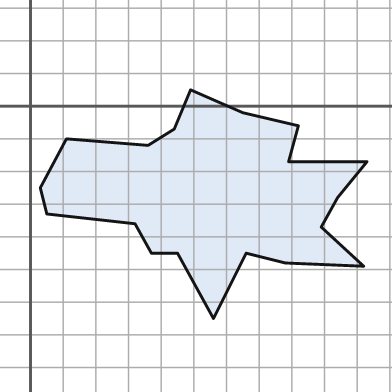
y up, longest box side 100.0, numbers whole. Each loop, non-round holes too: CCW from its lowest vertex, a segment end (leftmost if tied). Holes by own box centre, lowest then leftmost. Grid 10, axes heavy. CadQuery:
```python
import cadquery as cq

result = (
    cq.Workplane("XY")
    .moveTo(56.0, -65.0)
    .lineTo(66.0, -45.0)
    .lineTo(78.0, -48.0)
    .lineTo(102.0, -49.0)
    .lineTo(89.0, -37.0)
    .lineTo(94.0, -28.0)
    .lineTo(103.0, -17.0)
    .lineTo(79.0, -17.0)
    .lineTo(82.0, -6.0)
    .lineTo(65.0, -2.0)
    .lineTo(49.0, 5.0)
    .lineTo(44.0, -7.0)
    .lineTo(36.0, -12.0)
    .lineTo(11.0, -10.0)
    .lineTo(3.0, -25.0)
    .lineTo(5.0, -33.0)
    .lineTo(32.0, -36.0)
    .lineTo(37.0, -45.0)
    .lineTo(45.0, -45.0)
    .close()
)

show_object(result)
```